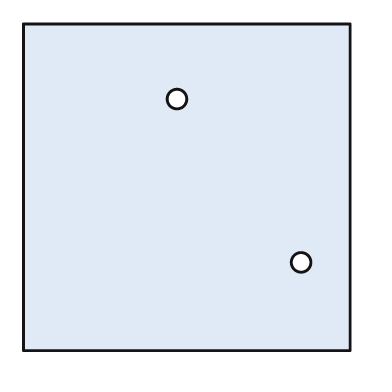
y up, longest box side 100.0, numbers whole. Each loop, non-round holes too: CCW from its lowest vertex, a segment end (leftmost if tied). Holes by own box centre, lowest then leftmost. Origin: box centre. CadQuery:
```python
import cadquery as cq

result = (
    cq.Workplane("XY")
    .moveTo(-50.0, -50.0)
    .lineTo(50.0, -50.0)
    .lineTo(50.0, 50.0)
    .lineTo(-50.0, 50.0)
    .close()
    .moveTo(35.0, -23.0)
    .circle(3.0)
    .moveTo(-3.0, 27.0)
    .circle(3.0)
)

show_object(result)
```